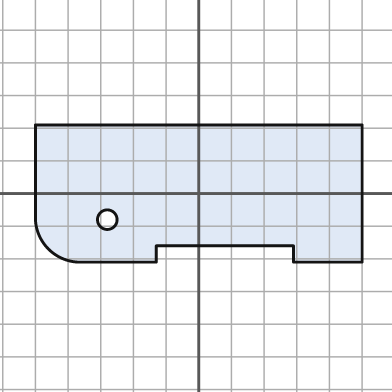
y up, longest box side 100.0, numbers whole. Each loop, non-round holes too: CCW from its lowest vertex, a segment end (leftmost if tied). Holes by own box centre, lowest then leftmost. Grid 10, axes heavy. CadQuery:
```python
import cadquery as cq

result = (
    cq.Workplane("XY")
    .moveTo(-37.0, -21.0)
    .lineTo(-13.0, -21.0)
    .lineTo(-13.0, -16.0)
    .lineTo(29.0, -16.0)
    .lineTo(29.0, -21.0)
    .lineTo(50.0, -21.0)
    .lineTo(50.0, 21.0)
    .lineTo(-50.0, 21.0)
    .lineTo(-50.0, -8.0)
    .threePointArc((-46.0, -17.0), (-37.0, -21.0))
    .close()
    .moveTo(-28.0, -8.0)
    .circle(3.0)
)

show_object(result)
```